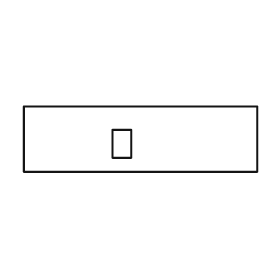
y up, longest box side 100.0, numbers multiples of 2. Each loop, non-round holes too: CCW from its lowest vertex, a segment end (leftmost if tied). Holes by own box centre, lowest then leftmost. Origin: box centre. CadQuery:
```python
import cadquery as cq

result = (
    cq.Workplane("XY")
    .moveTo(-50.0, -14.0)
    .lineTo(50.0, -14.0)
    .lineTo(50.0, 14.0)
    .lineTo(-50.0, 14.0)
    .close()
    .moveTo(-12.0, -8.0)
    .lineTo(-4.0, -8.0)
    .lineTo(-4.0, 4.0)
    .lineTo(-12.0, 4.0)
    .close()
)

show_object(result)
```